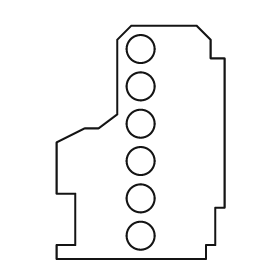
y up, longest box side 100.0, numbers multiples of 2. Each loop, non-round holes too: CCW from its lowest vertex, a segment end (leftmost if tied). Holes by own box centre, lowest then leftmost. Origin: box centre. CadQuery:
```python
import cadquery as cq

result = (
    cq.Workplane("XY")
    .moveTo(-36.0, -50.0)
    .lineTo(28.0, -50.0)
    .lineTo(28.0, -44.0)
    .lineTo(32.0, -44.0)
    .lineTo(32.0, -28.0)
    .lineTo(36.0, -28.0)
    .lineTo(36.0, 36.0)
    .lineTo(30.0, 36.0)
    .lineTo(30.0, 44.0)
    .lineTo(24.0, 50.0)
    .lineTo(-4.0, 50.0)
    .lineTo(-10.0, 44.0)
    .lineTo(-10.0, 12.0)
    .lineTo(-18.0, 6.0)
    .lineTo(-24.0, 6.0)
    .lineTo(-36.0, 0.0)
    .lineTo(-36.0, -22.0)
    .lineTo(-28.0, -22.0)
    .lineTo(-28.0, -44.0)
    .lineTo(-36.0, -44.0)
    .close()
    .moveTo(0.0, -40.0)
    .circle(6.0)
    .moveTo(0.0, -24.0)
    .circle(6.0)
    .moveTo(0.0, -8.0)
    .circle(6.0)
    .moveTo(0.0, 8.0)
    .circle(6.0)
    .moveTo(0.0, 24.0)
    .circle(6.0)
    .moveTo(0.0, 40.0)
    .circle(6.0)
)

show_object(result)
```